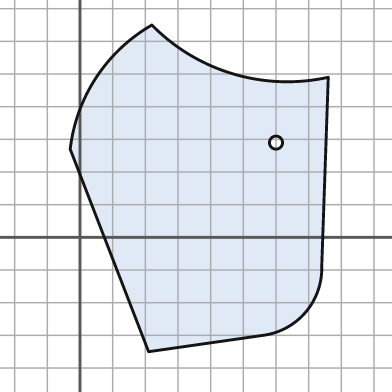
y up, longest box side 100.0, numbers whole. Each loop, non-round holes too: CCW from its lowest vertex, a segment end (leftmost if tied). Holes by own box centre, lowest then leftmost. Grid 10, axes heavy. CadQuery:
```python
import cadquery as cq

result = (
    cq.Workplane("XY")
    .moveTo(21.0, -35.0)
    .lineTo(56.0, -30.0)
    .threePointArc((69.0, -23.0), (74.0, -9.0))
    .lineTo(76.0, 49.0)
    .threePointArc((47.0, 50.0), (22.0, 65.0))
    .threePointArc((5.0, 49.0), (-3.0, 27.0))
    .close()
    .moveTo(60.0, 29.0)
    .circle(2.0)
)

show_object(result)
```